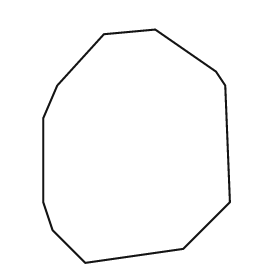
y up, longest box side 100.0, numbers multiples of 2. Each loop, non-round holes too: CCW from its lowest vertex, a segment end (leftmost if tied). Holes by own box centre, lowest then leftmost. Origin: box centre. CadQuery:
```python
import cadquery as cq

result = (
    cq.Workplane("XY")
    .moveTo(-22.0, -50.0)
    .lineTo(20.0, -44.0)
    .lineTo(40.0, -24.0)
    .lineTo(38.0, 26.0)
    .lineTo(34.0, 32.0)
    .lineTo(8.0, 50.0)
    .lineTo(-14.0, 48.0)
    .lineTo(-34.0, 26.0)
    .lineTo(-40.0, 12.0)
    .lineTo(-40.0, -24.0)
    .lineTo(-36.0, -36.0)
    .close()
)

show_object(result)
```